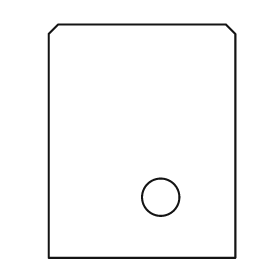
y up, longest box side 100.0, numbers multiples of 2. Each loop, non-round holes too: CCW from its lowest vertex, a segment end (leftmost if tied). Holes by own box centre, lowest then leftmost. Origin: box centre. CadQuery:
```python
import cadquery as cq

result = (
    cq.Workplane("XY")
    .moveTo(-40.0, -50.0)
    .lineTo(40.0, -50.0)
    .lineTo(40.0, 46.0)
    .lineTo(36.0, 50.0)
    .lineTo(-36.0, 50.0)
    .lineTo(-40.0, 46.0)
    .close()
    .moveTo(8.0, -24.0)
    .circle(8.0)
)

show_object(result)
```